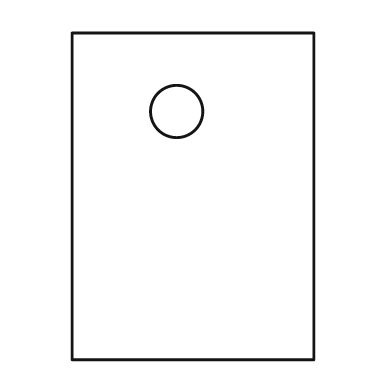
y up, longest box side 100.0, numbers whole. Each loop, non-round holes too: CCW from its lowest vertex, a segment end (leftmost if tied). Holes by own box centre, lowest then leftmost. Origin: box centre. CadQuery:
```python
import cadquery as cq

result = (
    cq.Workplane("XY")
    .moveTo(-37.0, -50.0)
    .lineTo(37.0, -50.0)
    .lineTo(37.0, 50.0)
    .lineTo(-37.0, 50.0)
    .close()
    .moveTo(-5.0, 26.0)
    .circle(8.0)
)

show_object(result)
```